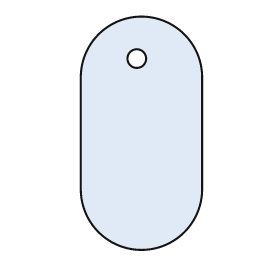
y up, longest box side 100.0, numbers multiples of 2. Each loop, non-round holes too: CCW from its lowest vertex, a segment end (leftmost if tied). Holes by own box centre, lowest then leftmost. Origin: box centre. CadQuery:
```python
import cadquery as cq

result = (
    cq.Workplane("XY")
    .moveTo(-26.0, -24.0)
    .threePointArc((0.0, -50.0), (26.0, -24.0))
    .lineTo(26.0, 24.0)
    .threePointArc((0.0, 50.0), (-26.0, 24.0))
    .close()
    .moveTo(-2.0, 32.0)
    .circle(4.0)
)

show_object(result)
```